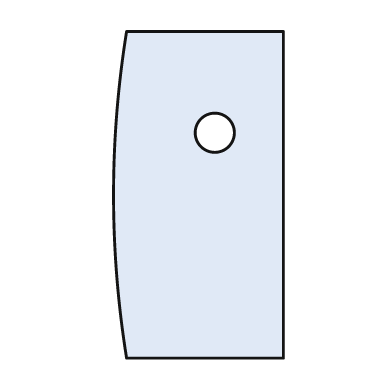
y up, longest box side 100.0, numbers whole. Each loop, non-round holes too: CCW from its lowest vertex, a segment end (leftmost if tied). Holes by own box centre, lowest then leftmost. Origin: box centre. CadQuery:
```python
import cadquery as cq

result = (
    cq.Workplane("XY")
    .moveTo(-22.0, -50.0)
    .lineTo(26.0, -50.0)
    .lineTo(26.0, 50.0)
    .lineTo(-22.0, 50.0)
    .threePointArc((-26.0, 0.0), (-22.0, -50.0))
    .close()
    .moveTo(5.0, 19.0)
    .circle(6.0)
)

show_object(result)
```